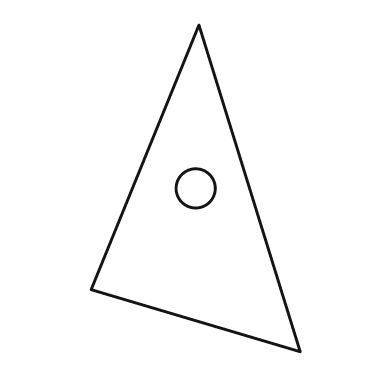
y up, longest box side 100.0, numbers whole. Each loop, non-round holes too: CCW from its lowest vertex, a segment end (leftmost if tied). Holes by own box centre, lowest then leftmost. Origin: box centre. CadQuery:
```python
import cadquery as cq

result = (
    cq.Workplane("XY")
    .moveTo(32.0, -50.0)
    .lineTo(1.0, 50.0)
    .lineTo(-32.0, -31.0)
    .close()
    .moveTo(0.0, 0.0)
    .circle(6.0)
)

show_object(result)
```